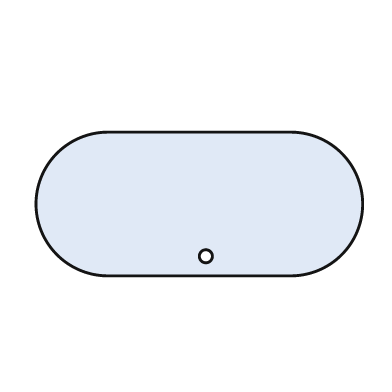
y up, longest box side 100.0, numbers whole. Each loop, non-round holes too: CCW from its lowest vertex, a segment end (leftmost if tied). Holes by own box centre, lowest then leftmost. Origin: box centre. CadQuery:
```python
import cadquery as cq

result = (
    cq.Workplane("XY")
    .moveTo(-28.0, -22.0)
    .lineTo(28.0, -22.0)
    .threePointArc((50.0, 0.0), (28.0, 22.0))
    .lineTo(-28.0, 22.0)
    .threePointArc((-50.0, 0.0), (-28.0, -22.0))
    .close()
    .moveTo(2.0, -16.0)
    .circle(2.0)
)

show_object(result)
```